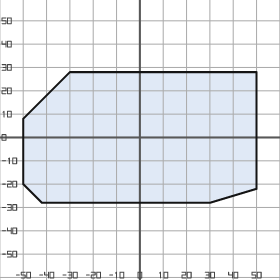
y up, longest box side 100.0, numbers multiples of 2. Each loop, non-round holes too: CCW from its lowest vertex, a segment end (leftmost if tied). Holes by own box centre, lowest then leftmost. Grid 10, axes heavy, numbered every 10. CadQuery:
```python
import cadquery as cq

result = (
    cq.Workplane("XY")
    .moveTo(-42.0, -28.0)
    .lineTo(30.0, -28.0)
    .lineTo(50.0, -22.0)
    .lineTo(50.0, 28.0)
    .lineTo(-30.0, 28.0)
    .lineTo(-50.0, 8.0)
    .lineTo(-50.0, -20.0)
    .close()
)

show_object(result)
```